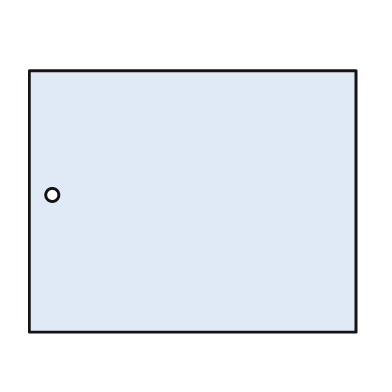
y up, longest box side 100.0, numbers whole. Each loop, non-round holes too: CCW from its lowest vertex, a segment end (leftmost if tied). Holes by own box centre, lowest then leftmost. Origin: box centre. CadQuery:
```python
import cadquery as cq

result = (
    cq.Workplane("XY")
    .moveTo(-50.0, -40.0)
    .lineTo(50.0, -40.0)
    .lineTo(50.0, 40.0)
    .lineTo(-50.0, 40.0)
    .close()
    .moveTo(-43.0, 2.0)
    .circle(2.0)
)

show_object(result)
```